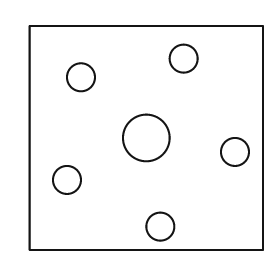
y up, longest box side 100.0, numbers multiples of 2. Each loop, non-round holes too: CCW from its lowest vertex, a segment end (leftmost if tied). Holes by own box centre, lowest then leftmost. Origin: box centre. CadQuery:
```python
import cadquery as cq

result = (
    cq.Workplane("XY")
    .moveTo(-50.0, -48.0)
    .lineTo(50.0, -48.0)
    .lineTo(50.0, 48.0)
    .lineTo(-50.0, 48.0)
    .close()
    .moveTo(6.0, -38.0)
    .circle(6.0)
    .moveTo(-34.0, -18.0)
    .circle(6.0)
    .moveTo(38.0, -6.0)
    .circle(6.0)
    .moveTo(0.0, 0.0)
    .circle(10.0)
    .moveTo(-28.0, 26.0)
    .circle(6.0)
    .moveTo(16.0, 34.0)
    .circle(6.0)
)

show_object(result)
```